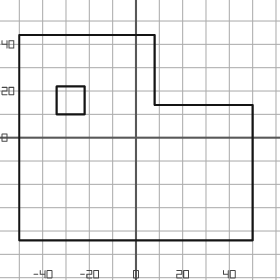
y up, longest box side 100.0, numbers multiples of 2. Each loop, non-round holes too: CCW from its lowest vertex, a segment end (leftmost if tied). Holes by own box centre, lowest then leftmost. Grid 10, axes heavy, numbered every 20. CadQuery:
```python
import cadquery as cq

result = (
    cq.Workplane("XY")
    .moveTo(-50.0, -44.0)
    .lineTo(50.0, -44.0)
    .lineTo(50.0, 14.0)
    .lineTo(8.0, 14.0)
    .lineTo(8.0, 44.0)
    .lineTo(-50.0, 44.0)
    .close()
    .moveTo(-34.0, 10.0)
    .lineTo(-22.0, 10.0)
    .lineTo(-22.0, 22.0)
    .lineTo(-34.0, 22.0)
    .close()
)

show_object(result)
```